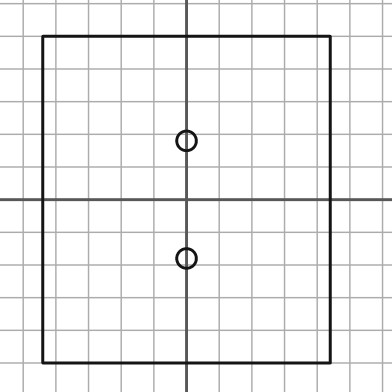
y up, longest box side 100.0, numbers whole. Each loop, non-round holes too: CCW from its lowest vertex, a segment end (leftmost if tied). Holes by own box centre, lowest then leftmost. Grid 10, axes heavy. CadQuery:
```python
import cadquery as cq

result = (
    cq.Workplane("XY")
    .moveTo(-44.0, -50.0)
    .lineTo(44.0, -50.0)
    .lineTo(44.0, 50.0)
    .lineTo(-44.0, 50.0)
    .close()
    .moveTo(0.0, -18.0)
    .circle(3.0)
    .moveTo(0.0, 18.0)
    .circle(3.0)
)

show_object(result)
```